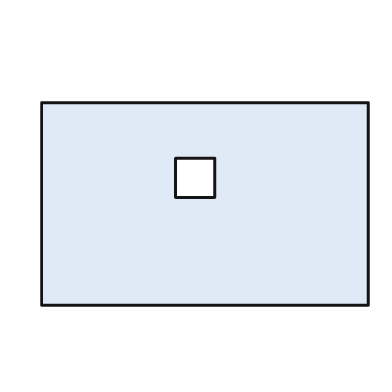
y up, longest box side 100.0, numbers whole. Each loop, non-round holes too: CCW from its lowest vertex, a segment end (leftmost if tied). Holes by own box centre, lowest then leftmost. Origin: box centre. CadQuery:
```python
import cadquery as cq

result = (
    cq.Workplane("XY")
    .moveTo(-50.0, -31.0)
    .lineTo(50.0, -31.0)
    .lineTo(50.0, 31.0)
    .lineTo(-50.0, 31.0)
    .close()
    .moveTo(-9.0, 2.0)
    .lineTo(3.0, 2.0)
    .lineTo(3.0, 14.0)
    .lineTo(-9.0, 14.0)
    .close()
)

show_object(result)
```